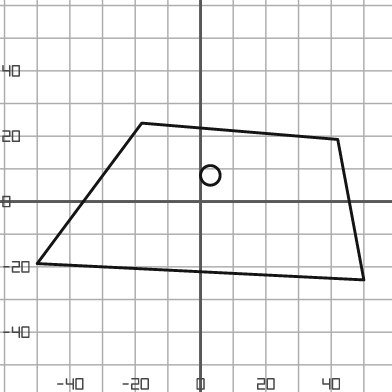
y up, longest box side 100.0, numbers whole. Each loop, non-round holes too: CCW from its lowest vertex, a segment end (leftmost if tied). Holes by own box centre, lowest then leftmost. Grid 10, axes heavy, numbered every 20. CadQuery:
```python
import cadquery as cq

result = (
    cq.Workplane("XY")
    .moveTo(50.0, -24.0)
    .lineTo(42.0, 19.0)
    .lineTo(-18.0, 24.0)
    .lineTo(-50.0, -19.0)
    .close()
    .moveTo(3.0, 8.0)
    .circle(3.0)
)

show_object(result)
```